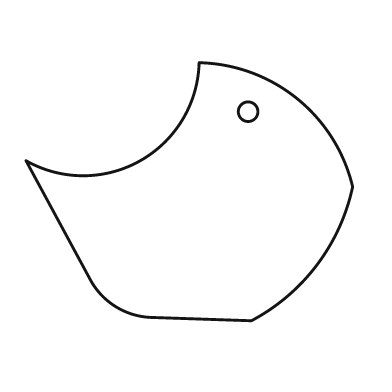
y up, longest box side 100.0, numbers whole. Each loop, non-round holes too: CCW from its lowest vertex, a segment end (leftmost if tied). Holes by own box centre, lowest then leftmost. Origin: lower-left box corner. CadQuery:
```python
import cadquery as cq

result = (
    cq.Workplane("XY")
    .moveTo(69.0, 0.0)
    .threePointArc((89.0, 17.0), (100.0, 41.0))
    .threePointArc((83.0, 68.0), (53.0, 79.0))
    .threePointArc((35.0, 49.0), (0.0, 49.0))
    .lineTo(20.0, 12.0)
    .threePointArc((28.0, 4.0), (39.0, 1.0))
    .close()
    .moveTo(68.0, 64.0)
    .circle(3.0)
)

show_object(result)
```